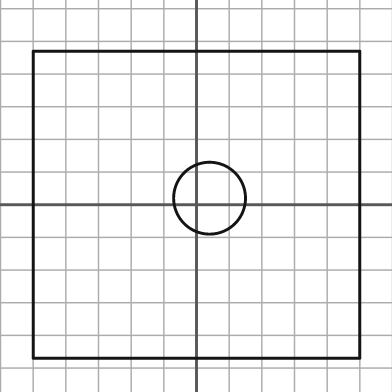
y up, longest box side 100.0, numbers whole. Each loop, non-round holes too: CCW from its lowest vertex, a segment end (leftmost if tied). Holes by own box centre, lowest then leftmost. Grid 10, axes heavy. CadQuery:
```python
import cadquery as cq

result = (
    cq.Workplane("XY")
    .moveTo(-50.0, -47.0)
    .lineTo(50.0, -47.0)
    .lineTo(50.0, 47.0)
    .lineTo(-50.0, 47.0)
    .close()
    .moveTo(4.0, 2.0)
    .circle(11.0)
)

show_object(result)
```